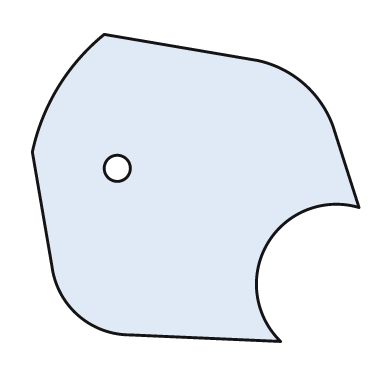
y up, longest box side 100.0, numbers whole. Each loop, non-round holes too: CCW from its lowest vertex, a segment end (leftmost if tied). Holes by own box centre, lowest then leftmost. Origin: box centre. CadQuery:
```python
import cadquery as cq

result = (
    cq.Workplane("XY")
    .moveTo(26.0, -47.0)
    .threePointArc((22.0, -17.0), (50.0, -6.0))
    .lineTo(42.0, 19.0)
    .threePointArc((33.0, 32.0), (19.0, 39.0))
    .lineTo(-28.0, 47.0)
    .threePointArc((-42.0, 31.0), (-50.0, 11.0))
    .lineTo(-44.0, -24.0)
    .threePointArc((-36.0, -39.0), (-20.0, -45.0))
    .close()
    .moveTo(-24.0, 6.0)
    .circle(4.0)
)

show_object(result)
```